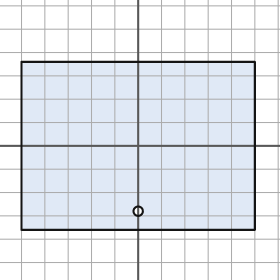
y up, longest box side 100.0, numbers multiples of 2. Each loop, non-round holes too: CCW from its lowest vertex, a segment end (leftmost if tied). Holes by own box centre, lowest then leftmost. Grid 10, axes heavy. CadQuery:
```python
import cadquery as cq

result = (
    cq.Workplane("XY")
    .moveTo(-50.0, -36.0)
    .lineTo(50.0, -36.0)
    .lineTo(50.0, 36.0)
    .lineTo(-50.0, 36.0)
    .close()
    .moveTo(0.0, -28.0)
    .circle(2.0)
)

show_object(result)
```